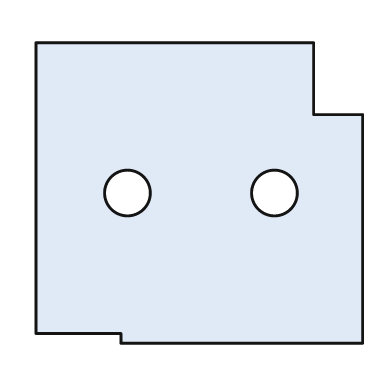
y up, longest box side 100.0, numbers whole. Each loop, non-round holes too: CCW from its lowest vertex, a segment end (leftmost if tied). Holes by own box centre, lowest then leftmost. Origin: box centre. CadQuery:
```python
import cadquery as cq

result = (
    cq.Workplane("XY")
    .moveTo(-24.0, -46.0)
    .lineTo(50.0, -46.0)
    .lineTo(50.0, 24.0)
    .lineTo(35.0, 24.0)
    .lineTo(35.0, 46.0)
    .lineTo(-50.0, 46.0)
    .lineTo(-50.0, -43.0)
    .lineTo(-24.0, -43.0)
    .close()
    .moveTo(-22.0, 0.0)
    .circle(7.0)
    .moveTo(23.0, 0.0)
    .circle(7.0)
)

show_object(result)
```